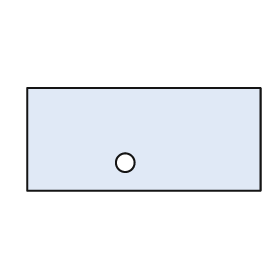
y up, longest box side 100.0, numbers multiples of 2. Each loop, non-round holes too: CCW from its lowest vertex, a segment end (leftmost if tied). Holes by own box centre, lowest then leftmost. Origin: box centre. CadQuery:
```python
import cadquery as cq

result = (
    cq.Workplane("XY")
    .moveTo(-50.0, -22.0)
    .lineTo(50.0, -22.0)
    .lineTo(50.0, 22.0)
    .lineTo(-50.0, 22.0)
    .close()
    .moveTo(-8.0, -10.0)
    .circle(4.0)
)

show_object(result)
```